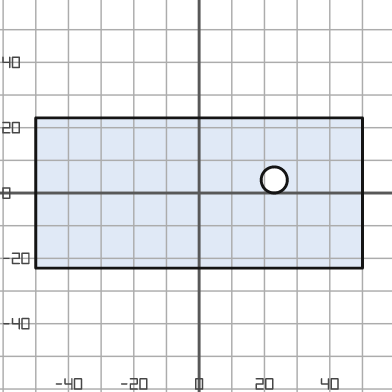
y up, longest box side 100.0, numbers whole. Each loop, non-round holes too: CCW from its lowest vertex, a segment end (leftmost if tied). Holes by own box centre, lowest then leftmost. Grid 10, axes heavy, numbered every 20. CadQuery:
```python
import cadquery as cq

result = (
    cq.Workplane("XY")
    .moveTo(-50.0, -23.0)
    .lineTo(50.0, -23.0)
    .lineTo(50.0, 23.0)
    .lineTo(-50.0, 23.0)
    .close()
    .moveTo(23.0, 4.0)
    .circle(4.0)
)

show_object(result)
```